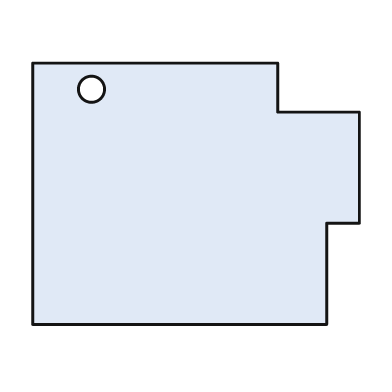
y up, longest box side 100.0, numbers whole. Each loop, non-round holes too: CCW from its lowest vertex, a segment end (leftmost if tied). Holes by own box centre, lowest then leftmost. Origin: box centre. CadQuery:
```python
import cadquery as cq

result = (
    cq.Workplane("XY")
    .moveTo(-50.0, -40.0)
    .lineTo(40.0, -40.0)
    .lineTo(40.0, -9.0)
    .lineTo(50.0, -9.0)
    .lineTo(50.0, 25.0)
    .lineTo(25.0, 25.0)
    .lineTo(25.0, 40.0)
    .lineTo(-50.0, 40.0)
    .close()
    .moveTo(-32.0, 32.0)
    .circle(4.0)
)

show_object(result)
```